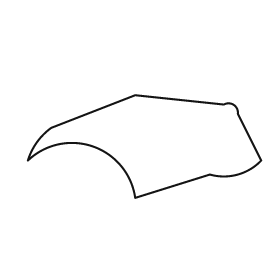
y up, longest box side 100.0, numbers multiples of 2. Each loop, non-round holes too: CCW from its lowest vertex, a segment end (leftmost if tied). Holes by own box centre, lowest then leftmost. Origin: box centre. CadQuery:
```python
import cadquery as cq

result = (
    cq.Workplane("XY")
    .moveTo(-4.0, -22.0)
    .lineTo(28.0, -12.0)
    .threePointArc((40.0, -12.0), (50.0, -6.0))
    .lineTo(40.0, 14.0)
    .threePointArc((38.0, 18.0), (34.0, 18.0))
    .lineTo(-4.0, 22.0)
    .lineTo(-40.0, 8.0)
    .threePointArc((-46.0, 2.0), (-50.0, -6.0))
    .threePointArc((-22.0, 0.0), (-4.0, -22.0))
    .close()
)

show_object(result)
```